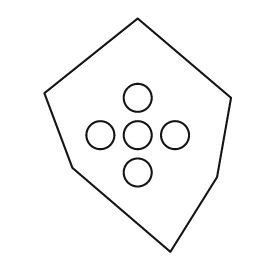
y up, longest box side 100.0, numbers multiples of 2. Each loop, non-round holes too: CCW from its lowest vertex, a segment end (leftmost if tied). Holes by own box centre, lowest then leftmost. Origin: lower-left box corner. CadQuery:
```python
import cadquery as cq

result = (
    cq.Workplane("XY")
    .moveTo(54.0, 0.0)
    .lineTo(74.0, 32.0)
    .lineTo(80.0, 66.0)
    .lineTo(40.0, 100.0)
    .lineTo(0.0, 68.0)
    .lineTo(12.0, 36.0)
    .close()
    .moveTo(40.0, 34.0)
    .circle(6.0)
    .moveTo(24.0, 50.0)
    .circle(6.0)
    .moveTo(40.0, 50.0)
    .circle(6.0)
    .moveTo(56.0, 50.0)
    .circle(6.0)
    .moveTo(40.0, 66.0)
    .circle(6.0)
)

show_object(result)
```